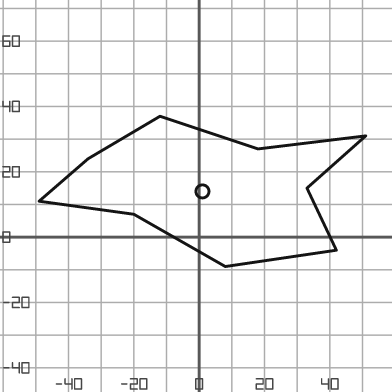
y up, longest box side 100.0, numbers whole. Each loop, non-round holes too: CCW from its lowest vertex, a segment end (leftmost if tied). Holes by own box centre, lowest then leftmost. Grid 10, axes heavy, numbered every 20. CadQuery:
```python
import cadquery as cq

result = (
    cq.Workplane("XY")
    .moveTo(8.0, -9.0)
    .lineTo(42.0, -4.0)
    .lineTo(33.0, 15.0)
    .lineTo(51.0, 31.0)
    .lineTo(18.0, 27.0)
    .lineTo(-12.0, 37.0)
    .lineTo(-34.0, 24.0)
    .lineTo(-49.0, 11.0)
    .lineTo(-20.0, 7.0)
    .close()
    .moveTo(1.0, 14.0)
    .circle(2.0)
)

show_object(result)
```